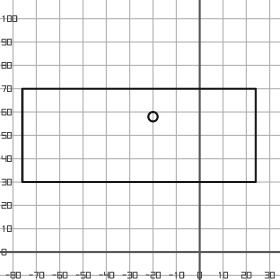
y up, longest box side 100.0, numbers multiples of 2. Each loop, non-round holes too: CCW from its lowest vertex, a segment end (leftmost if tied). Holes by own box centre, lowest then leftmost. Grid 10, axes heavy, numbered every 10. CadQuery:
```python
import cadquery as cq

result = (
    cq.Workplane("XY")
    .moveTo(-76.0, 30.0)
    .lineTo(24.0, 30.0)
    .lineTo(24.0, 70.0)
    .lineTo(-76.0, 70.0)
    .close()
    .moveTo(-20.0, 58.0)
    .circle(2.0)
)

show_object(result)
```